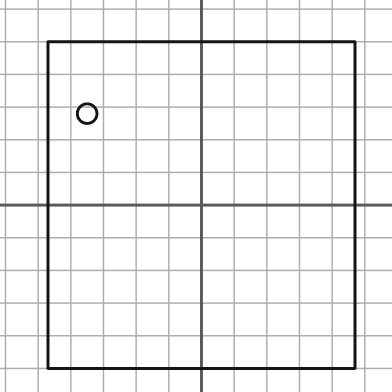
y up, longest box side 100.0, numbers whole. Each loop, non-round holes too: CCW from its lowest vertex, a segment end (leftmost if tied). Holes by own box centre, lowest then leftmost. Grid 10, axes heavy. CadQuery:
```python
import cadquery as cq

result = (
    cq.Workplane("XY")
    .moveTo(-47.0, -50.0)
    .lineTo(47.0, -50.0)
    .lineTo(47.0, 50.0)
    .lineTo(-47.0, 50.0)
    .close()
    .moveTo(-35.0, 28.0)
    .circle(3.0)
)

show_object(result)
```